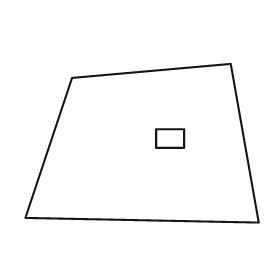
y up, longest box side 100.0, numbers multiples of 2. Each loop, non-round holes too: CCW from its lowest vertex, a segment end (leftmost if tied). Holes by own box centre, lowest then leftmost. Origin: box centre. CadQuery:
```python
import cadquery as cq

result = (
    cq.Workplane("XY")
    .moveTo(50.0, -34.0)
    .lineTo(38.0, 34.0)
    .lineTo(-30.0, 28.0)
    .lineTo(-50.0, -32.0)
    .close()
    .moveTo(6.0, -2.0)
    .lineTo(18.0, -2.0)
    .lineTo(18.0, 6.0)
    .lineTo(6.0, 6.0)
    .close()
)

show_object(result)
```